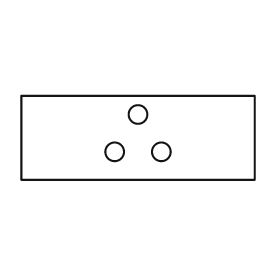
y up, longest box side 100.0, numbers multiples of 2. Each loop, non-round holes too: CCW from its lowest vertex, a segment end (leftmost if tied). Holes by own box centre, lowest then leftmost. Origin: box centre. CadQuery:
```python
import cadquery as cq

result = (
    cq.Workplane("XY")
    .moveTo(-50.0, -18.0)
    .lineTo(50.0, -18.0)
    .lineTo(50.0, 18.0)
    .lineTo(-50.0, 18.0)
    .close()
    .moveTo(-10.0, -6.0)
    .circle(4.0)
    .moveTo(10.0, -6.0)
    .circle(4.0)
    .moveTo(0.0, 10.0)
    .circle(4.0)
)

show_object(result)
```